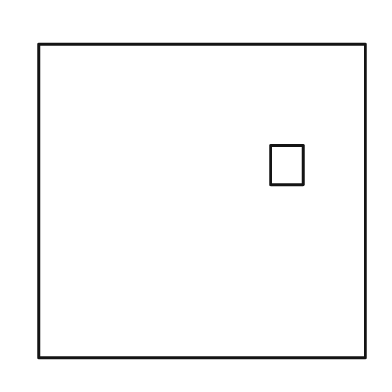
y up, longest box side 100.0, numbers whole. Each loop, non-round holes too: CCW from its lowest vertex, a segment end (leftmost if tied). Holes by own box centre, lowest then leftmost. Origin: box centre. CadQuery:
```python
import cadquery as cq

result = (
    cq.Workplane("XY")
    .moveTo(-50.0, -48.0)
    .lineTo(50.0, -48.0)
    .lineTo(50.0, 48.0)
    .lineTo(-50.0, 48.0)
    .close()
    .moveTo(21.0, 5.0)
    .lineTo(31.0, 5.0)
    .lineTo(31.0, 17.0)
    .lineTo(21.0, 17.0)
    .close()
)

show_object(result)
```